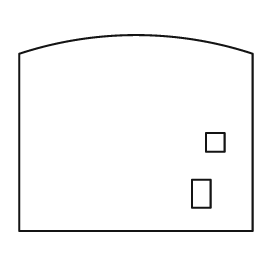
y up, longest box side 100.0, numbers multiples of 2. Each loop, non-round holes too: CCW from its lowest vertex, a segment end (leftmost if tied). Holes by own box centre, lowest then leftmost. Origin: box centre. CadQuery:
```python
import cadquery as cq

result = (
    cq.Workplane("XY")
    .moveTo(-50.0, -42.0)
    .lineTo(50.0, -42.0)
    .lineTo(50.0, 34.0)
    .threePointArc((0.0, 42.0), (-50.0, 34.0))
    .close()
    .moveTo(24.0, -32.0)
    .lineTo(32.0, -32.0)
    .lineTo(32.0, -20.0)
    .lineTo(24.0, -20.0)
    .close()
    .moveTo(30.0, -8.0)
    .lineTo(38.0, -8.0)
    .lineTo(38.0, 0.0)
    .lineTo(30.0, 0.0)
    .close()
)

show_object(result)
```